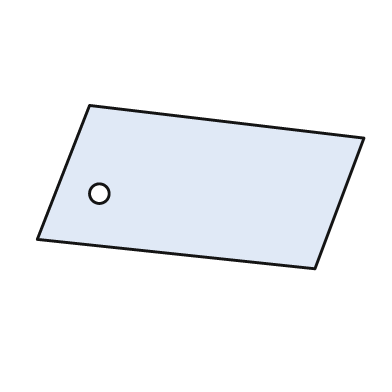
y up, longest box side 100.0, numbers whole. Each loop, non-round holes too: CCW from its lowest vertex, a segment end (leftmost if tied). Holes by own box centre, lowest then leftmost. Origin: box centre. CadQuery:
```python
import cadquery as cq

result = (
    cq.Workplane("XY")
    .moveTo(35.0, -25.0)
    .lineTo(50.0, 15.0)
    .lineTo(-34.0, 25.0)
    .lineTo(-50.0, -16.0)
    .close()
    .moveTo(-31.0, -2.0)
    .circle(3.0)
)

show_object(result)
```